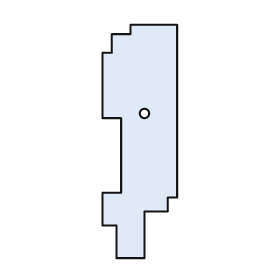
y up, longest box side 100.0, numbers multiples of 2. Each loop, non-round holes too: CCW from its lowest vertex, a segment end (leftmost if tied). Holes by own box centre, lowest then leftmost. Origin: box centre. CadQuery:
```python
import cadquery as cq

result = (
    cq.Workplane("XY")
    .moveTo(-10.0, -50.0)
    .lineTo(2.0, -50.0)
    .lineTo(2.0, -30.0)
    .lineTo(12.0, -30.0)
    .lineTo(12.0, -24.0)
    .lineTo(16.0, -24.0)
    .lineTo(16.0, 50.0)
    .lineTo(-4.0, 50.0)
    .lineTo(-4.0, 46.0)
    .lineTo(-12.0, 46.0)
    .lineTo(-12.0, 38.0)
    .lineTo(-16.0, 38.0)
    .lineTo(-16.0, 10.0)
    .lineTo(-8.0, 10.0)
    .lineTo(-8.0, -22.0)
    .lineTo(-16.0, -22.0)
    .lineTo(-16.0, -36.0)
    .lineTo(-10.0, -36.0)
    .close()
    .moveTo(2.0, 12.0)
    .circle(2.0)
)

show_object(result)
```